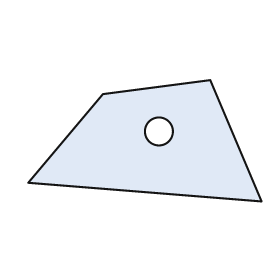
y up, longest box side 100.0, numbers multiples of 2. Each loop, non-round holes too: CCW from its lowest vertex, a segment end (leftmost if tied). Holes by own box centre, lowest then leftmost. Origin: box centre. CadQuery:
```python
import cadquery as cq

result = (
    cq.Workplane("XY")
    .moveTo(50.0, -26.0)
    .lineTo(28.0, 26.0)
    .lineTo(-18.0, 20.0)
    .lineTo(-50.0, -18.0)
    .close()
    .moveTo(6.0, 4.0)
    .circle(6.0)
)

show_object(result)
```